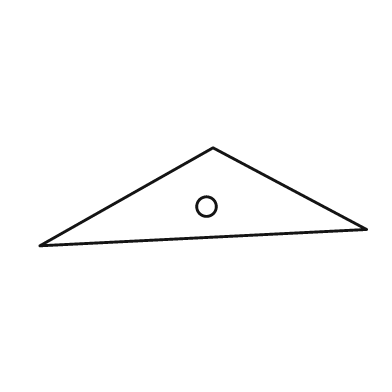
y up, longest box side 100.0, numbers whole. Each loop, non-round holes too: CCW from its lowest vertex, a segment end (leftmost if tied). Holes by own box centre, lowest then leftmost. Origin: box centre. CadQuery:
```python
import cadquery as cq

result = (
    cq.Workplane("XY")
    .moveTo(-50.0, -15.0)
    .lineTo(50.0, -10.0)
    .lineTo(3.0, 15.0)
    .close()
    .moveTo(1.0, -3.0)
    .circle(3.0)
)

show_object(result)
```